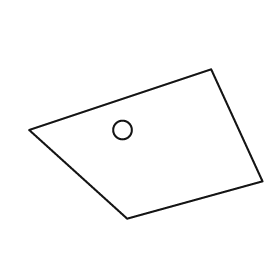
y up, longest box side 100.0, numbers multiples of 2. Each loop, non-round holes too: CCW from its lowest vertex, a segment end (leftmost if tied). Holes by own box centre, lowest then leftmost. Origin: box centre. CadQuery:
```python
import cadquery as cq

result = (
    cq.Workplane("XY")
    .moveTo(-8.0, -32.0)
    .lineTo(50.0, -16.0)
    .lineTo(28.0, 32.0)
    .lineTo(-50.0, 6.0)
    .close()
    .moveTo(-10.0, 6.0)
    .circle(4.0)
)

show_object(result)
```